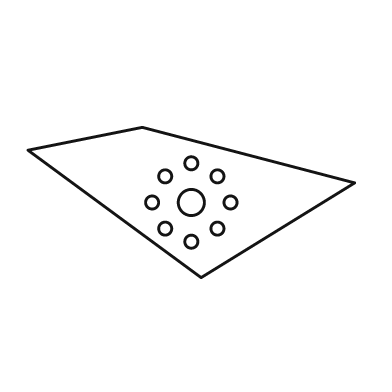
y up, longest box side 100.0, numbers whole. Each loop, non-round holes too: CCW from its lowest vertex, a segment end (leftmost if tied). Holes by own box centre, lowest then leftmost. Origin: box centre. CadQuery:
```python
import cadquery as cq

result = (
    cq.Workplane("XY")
    .moveTo(3.0, -23.0)
    .lineTo(50.0, 6.0)
    .lineTo(-15.0, 23.0)
    .lineTo(-50.0, 16.0)
    .close()
    .moveTo(0.0, -12.0)
    .circle(2.0)
    .moveTo(-8.0, -8.0)
    .circle(2.0)
    .moveTo(8.0, -8.0)
    .circle(2.0)
    .moveTo(-12.0, 0.0)
    .circle(2.0)
    .moveTo(0.0, 0.0)
    .circle(4.0)
    .moveTo(12.0, 0.0)
    .circle(2.0)
    .moveTo(-8.0, 8.0)
    .circle(2.0)
    .moveTo(8.0, 8.0)
    .circle(2.0)
    .moveTo(0.0, 12.0)
    .circle(2.0)
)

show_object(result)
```